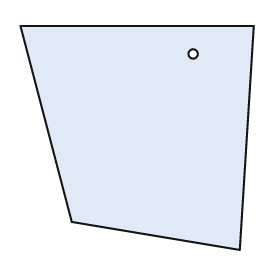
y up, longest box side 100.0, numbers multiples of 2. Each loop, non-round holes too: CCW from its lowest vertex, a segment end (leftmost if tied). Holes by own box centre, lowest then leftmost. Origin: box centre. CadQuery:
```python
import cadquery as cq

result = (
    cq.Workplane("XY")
    .moveTo(44.0, -48.0)
    .lineTo(50.0, 48.0)
    .lineTo(-50.0, 48.0)
    .lineTo(-28.0, -36.0)
    .close()
    .moveTo(24.0, 36.0)
    .circle(2.0)
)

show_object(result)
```